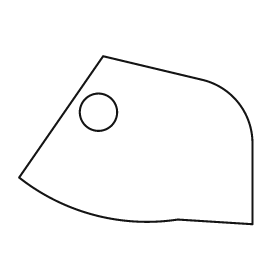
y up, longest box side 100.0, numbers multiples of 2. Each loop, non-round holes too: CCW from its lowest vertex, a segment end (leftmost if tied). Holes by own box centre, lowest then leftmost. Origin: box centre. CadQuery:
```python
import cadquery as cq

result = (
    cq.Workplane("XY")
    .moveTo(50.0, -36.0)
    .lineTo(50.0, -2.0)
    .threePointArc((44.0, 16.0), (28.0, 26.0))
    .lineTo(-14.0, 36.0)
    .lineTo(-50.0, -16.0)
    .threePointArc((-18.0, -32.0), (18.0, -34.0))
    .close()
    .moveTo(-16.0, 12.0)
    .circle(8.0)
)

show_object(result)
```